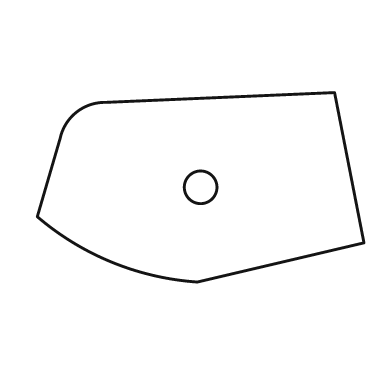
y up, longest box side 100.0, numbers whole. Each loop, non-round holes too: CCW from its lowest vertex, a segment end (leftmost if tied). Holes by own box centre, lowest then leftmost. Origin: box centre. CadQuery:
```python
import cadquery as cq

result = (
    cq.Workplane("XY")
    .moveTo(-1.0, -29.0)
    .lineTo(50.0, -17.0)
    .lineTo(41.0, 29.0)
    .lineTo(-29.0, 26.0)
    .threePointArc((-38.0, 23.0), (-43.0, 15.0))
    .lineTo(-50.0, -9.0)
    .threePointArc((-27.0, -23.0), (-1.0, -29.0))
    .close()
    .moveTo(0.0, 0.0)
    .circle(5.0)
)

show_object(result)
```